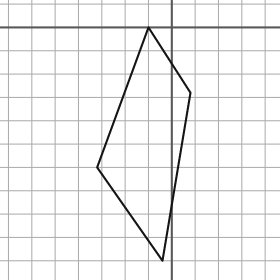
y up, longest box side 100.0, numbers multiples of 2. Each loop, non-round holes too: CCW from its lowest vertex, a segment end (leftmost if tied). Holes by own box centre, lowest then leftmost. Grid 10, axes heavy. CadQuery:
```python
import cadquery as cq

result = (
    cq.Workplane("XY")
    .moveTo(-4.0, -100.0)
    .lineTo(8.0, -28.0)
    .lineTo(-10.0, 0.0)
    .lineTo(-32.0, -60.0)
    .close()
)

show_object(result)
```